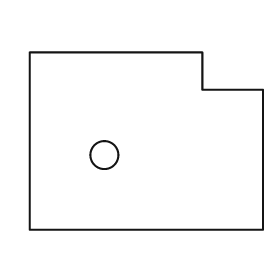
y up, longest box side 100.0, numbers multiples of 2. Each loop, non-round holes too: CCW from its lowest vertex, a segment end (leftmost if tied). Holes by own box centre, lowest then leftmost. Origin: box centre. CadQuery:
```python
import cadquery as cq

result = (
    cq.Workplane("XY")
    .moveTo(-50.0, -38.0)
    .lineTo(50.0, -38.0)
    .lineTo(50.0, 22.0)
    .lineTo(24.0, 22.0)
    .lineTo(24.0, 38.0)
    .lineTo(-50.0, 38.0)
    .close()
    .moveTo(-18.0, -6.0)
    .circle(6.0)
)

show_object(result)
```